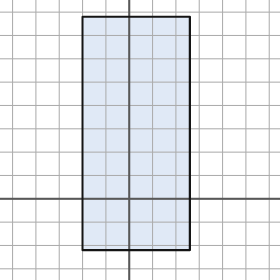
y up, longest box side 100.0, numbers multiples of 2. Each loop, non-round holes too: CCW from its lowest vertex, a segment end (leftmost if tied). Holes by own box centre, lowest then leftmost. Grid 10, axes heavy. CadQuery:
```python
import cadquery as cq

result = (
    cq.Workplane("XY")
    .moveTo(-20.0, -22.0)
    .lineTo(26.0, -22.0)
    .lineTo(26.0, 78.0)
    .lineTo(-20.0, 78.0)
    .close()
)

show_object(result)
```